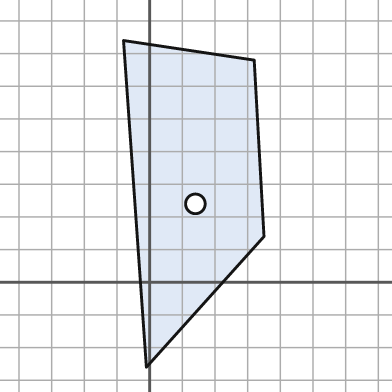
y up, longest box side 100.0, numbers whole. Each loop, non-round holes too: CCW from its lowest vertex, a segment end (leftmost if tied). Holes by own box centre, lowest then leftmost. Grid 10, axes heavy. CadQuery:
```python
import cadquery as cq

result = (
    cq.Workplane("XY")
    .moveTo(-1.0, -26.0)
    .lineTo(35.0, 14.0)
    .lineTo(32.0, 68.0)
    .lineTo(-8.0, 74.0)
    .close()
    .moveTo(14.0, 24.0)
    .circle(3.0)
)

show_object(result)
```